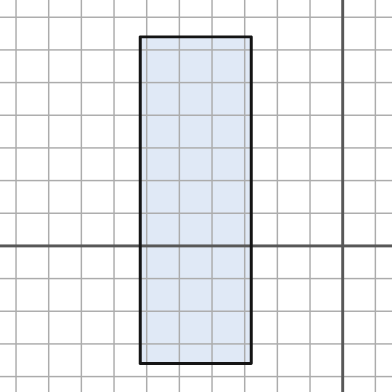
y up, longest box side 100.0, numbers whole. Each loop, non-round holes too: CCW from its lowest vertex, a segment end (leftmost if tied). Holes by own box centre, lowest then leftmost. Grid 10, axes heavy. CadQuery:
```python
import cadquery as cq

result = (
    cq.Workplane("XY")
    .moveTo(-62.0, -36.0)
    .lineTo(-28.0, -36.0)
    .lineTo(-28.0, 64.0)
    .lineTo(-62.0, 64.0)
    .close()
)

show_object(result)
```